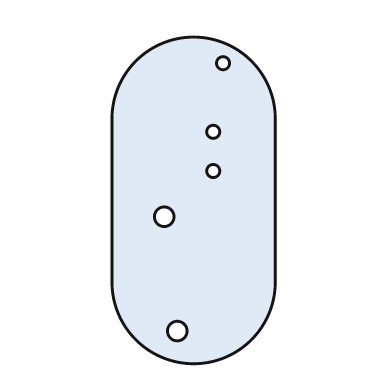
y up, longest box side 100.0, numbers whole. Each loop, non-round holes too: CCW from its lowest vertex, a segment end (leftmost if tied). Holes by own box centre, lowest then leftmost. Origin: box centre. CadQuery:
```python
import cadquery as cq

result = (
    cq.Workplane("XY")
    .moveTo(-25.0, -25.0)
    .threePointArc((0.0, -50.0), (25.0, -25.0))
    .lineTo(25.0, 25.0)
    .threePointArc((0.0, 50.0), (-25.0, 25.0))
    .close()
    .moveTo(-5.0, -40.0)
    .circle(3.0)
    .moveTo(-9.0, -5.0)
    .circle(3.0)
    .moveTo(6.0, 9.0)
    .circle(2.0)
    .moveTo(6.0, 21.0)
    .circle(2.0)
    .moveTo(9.0, 42.0)
    .circle(2.0)
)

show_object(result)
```